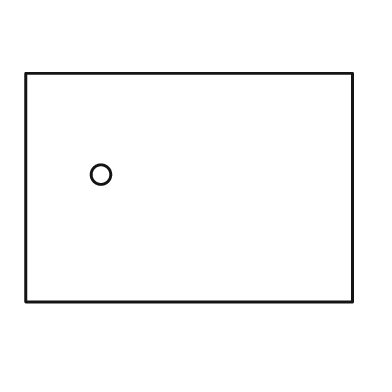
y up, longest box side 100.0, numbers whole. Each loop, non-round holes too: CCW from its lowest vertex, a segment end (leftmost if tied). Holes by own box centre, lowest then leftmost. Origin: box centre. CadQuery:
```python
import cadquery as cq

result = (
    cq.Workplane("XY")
    .moveTo(-50.0, -35.0)
    .lineTo(50.0, -35.0)
    .lineTo(50.0, 35.0)
    .lineTo(-50.0, 35.0)
    .close()
    .moveTo(-27.0, 4.0)
    .circle(3.0)
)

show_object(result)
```